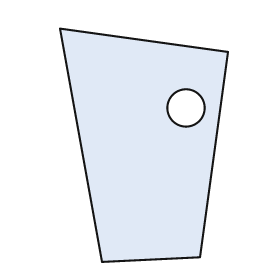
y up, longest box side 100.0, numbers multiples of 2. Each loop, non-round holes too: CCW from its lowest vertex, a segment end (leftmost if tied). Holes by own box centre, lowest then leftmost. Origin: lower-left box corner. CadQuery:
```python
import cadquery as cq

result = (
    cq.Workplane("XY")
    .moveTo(18.0, 0.0)
    .lineTo(60.0, 2.0)
    .lineTo(72.0, 90.0)
    .lineTo(0.0, 100.0)
    .close()
    .moveTo(54.0, 66.0)
    .circle(8.0)
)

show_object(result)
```